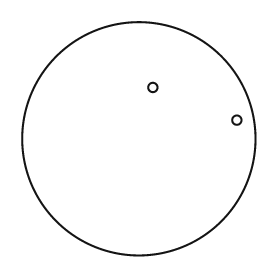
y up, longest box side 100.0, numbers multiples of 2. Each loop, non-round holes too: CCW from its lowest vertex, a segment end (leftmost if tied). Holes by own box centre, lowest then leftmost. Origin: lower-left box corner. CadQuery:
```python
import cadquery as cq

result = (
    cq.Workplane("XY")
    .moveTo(50.0, 50.0)
    .circle(50.0)
    .moveTo(92.0, 58.0)
    .circle(2.0)
    .moveTo(56.0, 72.0)
    .circle(2.0)
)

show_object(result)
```